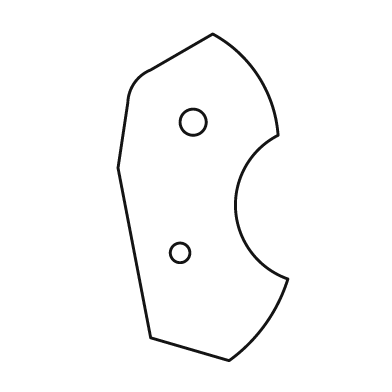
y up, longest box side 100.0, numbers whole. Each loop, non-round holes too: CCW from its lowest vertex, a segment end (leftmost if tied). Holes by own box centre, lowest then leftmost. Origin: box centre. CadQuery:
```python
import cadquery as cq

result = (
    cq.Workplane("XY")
    .moveTo(8.0, -50.0)
    .threePointArc((19.0, -39.0), (26.0, -25.0))
    .threePointArc((10.0, -4.0), (23.0, 19.0))
    .threePointArc((17.0, 37.0), (3.0, 50.0))
    .lineTo(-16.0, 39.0)
    .threePointArc((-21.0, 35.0), (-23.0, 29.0))
    .lineTo(-26.0, 9.0)
    .lineTo(-16.0, -43.0)
    .close()
    .moveTo(-7.0, -17.0)
    .circle(3.0)
    .moveTo(-3.0, 23.0)
    .circle(4.0)
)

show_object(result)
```